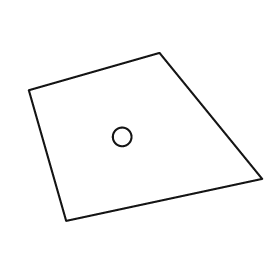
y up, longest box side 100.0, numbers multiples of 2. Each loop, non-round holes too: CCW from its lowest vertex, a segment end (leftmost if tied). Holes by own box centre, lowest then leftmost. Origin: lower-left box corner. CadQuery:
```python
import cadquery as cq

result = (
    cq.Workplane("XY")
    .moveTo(16.0, 0.0)
    .lineTo(100.0, 18.0)
    .lineTo(56.0, 72.0)
    .lineTo(0.0, 56.0)
    .close()
    .moveTo(40.0, 36.0)
    .circle(4.0)
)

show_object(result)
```